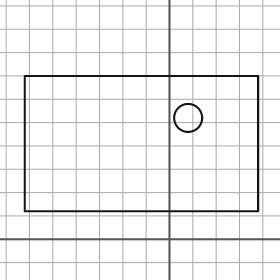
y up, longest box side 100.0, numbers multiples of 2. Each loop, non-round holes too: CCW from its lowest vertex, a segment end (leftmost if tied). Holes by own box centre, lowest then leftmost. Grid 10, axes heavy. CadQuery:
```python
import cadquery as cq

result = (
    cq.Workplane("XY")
    .moveTo(-62.0, 12.0)
    .lineTo(38.0, 12.0)
    .lineTo(38.0, 70.0)
    .lineTo(-62.0, 70.0)
    .close()
    .moveTo(8.0, 52.0)
    .circle(6.0)
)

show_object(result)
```